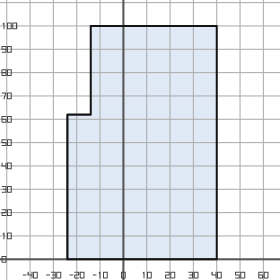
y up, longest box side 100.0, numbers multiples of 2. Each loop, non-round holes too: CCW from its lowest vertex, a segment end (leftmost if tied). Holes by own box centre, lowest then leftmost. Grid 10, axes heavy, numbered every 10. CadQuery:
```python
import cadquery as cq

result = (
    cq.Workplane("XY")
    .moveTo(-24.0, 0.0)
    .lineTo(40.0, 0.0)
    .lineTo(40.0, 100.0)
    .lineTo(-14.0, 100.0)
    .lineTo(-14.0, 62.0)
    .lineTo(-24.0, 62.0)
    .close()
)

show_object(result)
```